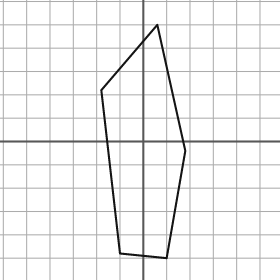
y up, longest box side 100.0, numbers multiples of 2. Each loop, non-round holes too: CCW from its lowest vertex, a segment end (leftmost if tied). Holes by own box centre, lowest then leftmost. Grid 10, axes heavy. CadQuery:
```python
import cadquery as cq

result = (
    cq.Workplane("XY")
    .moveTo(10.0, -50.0)
    .lineTo(18.0, -4.0)
    .lineTo(6.0, 50.0)
    .lineTo(-18.0, 22.0)
    .lineTo(-10.0, -48.0)
    .close()
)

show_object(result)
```